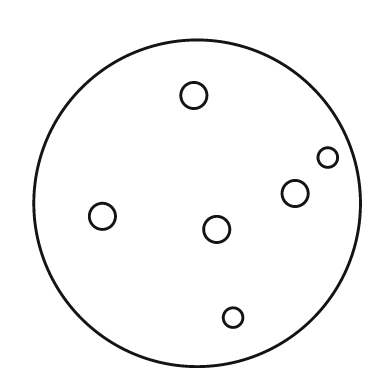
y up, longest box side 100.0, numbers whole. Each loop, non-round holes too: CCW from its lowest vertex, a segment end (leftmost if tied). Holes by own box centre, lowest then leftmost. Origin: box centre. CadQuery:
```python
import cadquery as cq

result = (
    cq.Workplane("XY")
    .moveTo(0.0, 0.0)
    .circle(50.0)
    .moveTo(11.0, -35.0)
    .circle(3.0)
    .moveTo(6.0, -8.0)
    .circle(4.0)
    .moveTo(-29.0, -4.0)
    .circle(4.0)
    .moveTo(30.0, 3.0)
    .circle(4.0)
    .moveTo(40.0, 14.0)
    .circle(3.0)
    .moveTo(-1.0, 33.0)
    .circle(4.0)
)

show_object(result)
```